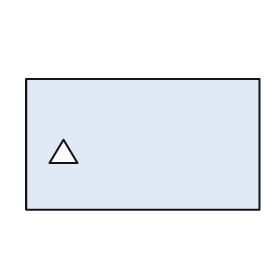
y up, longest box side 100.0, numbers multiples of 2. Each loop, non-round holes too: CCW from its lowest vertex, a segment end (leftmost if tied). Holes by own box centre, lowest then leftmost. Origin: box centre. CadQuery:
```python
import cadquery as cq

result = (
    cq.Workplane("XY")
    .moveTo(-50.0, -28.0)
    .lineTo(50.0, -28.0)
    .lineTo(50.0, 28.0)
    .lineTo(-50.0, 28.0)
    .close()
    .moveTo(-40.0, -8.0)
    .lineTo(-28.0, -8.0)
    .lineTo(-34.0, 2.0)
    .close()
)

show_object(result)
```